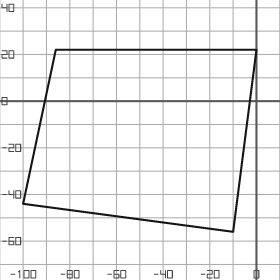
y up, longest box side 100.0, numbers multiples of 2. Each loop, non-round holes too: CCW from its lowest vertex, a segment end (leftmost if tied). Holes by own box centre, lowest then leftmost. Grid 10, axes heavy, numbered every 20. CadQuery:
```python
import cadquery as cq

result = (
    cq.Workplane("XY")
    .moveTo(-10.0, -56.0)
    .lineTo(0.0, 22.0)
    .lineTo(-86.0, 22.0)
    .lineTo(-100.0, -44.0)
    .close()
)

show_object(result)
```